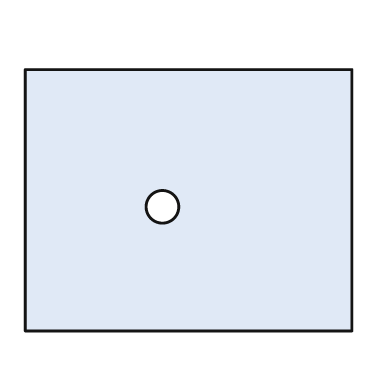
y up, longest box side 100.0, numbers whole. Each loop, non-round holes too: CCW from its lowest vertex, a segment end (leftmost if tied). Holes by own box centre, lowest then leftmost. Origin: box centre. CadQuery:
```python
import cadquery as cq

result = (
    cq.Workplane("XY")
    .moveTo(-50.0, -40.0)
    .lineTo(50.0, -40.0)
    .lineTo(50.0, 40.0)
    .lineTo(-50.0, 40.0)
    .close()
    .moveTo(-8.0, -2.0)
    .circle(5.0)
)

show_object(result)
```